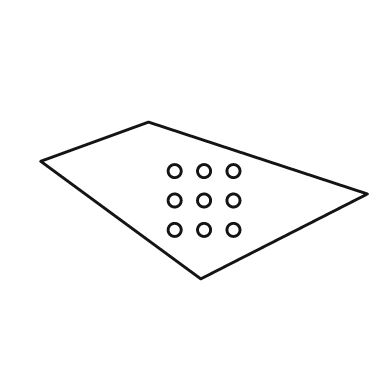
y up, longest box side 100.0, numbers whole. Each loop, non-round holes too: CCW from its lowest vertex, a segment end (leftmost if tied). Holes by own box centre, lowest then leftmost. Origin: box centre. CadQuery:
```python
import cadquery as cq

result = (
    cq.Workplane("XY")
    .moveTo(-1.0, -24.0)
    .lineTo(50.0, 2.0)
    .lineTo(-17.0, 24.0)
    .lineTo(-50.0, 12.0)
    .close()
    .moveTo(-9.0, -9.0)
    .circle(2.0)
    .moveTo(0.0, -9.0)
    .circle(2.0)
    .moveTo(9.0, -9.0)
    .circle(2.0)
    .moveTo(-9.0, 0.0)
    .circle(2.0)
    .moveTo(0.0, 0.0)
    .circle(2.0)
    .moveTo(9.0, 0.0)
    .circle(2.0)
    .moveTo(-9.0, 9.0)
    .circle(2.0)
    .moveTo(0.0, 9.0)
    .circle(2.0)
    .moveTo(9.0, 9.0)
    .circle(2.0)
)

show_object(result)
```